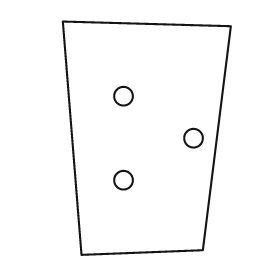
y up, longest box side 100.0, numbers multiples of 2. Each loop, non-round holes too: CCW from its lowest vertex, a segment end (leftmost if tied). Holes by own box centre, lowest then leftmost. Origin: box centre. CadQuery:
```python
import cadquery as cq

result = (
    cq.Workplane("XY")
    .moveTo(-28.0, -50.0)
    .lineTo(24.0, -48.0)
    .lineTo(36.0, 48.0)
    .lineTo(-36.0, 50.0)
    .close()
    .moveTo(-10.0, -18.0)
    .circle(4.0)
    .moveTo(20.0, 0.0)
    .circle(4.0)
    .moveTo(-10.0, 18.0)
    .circle(4.0)
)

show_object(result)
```